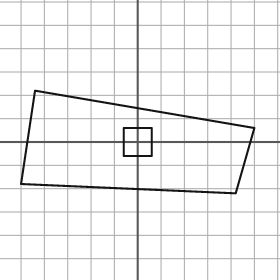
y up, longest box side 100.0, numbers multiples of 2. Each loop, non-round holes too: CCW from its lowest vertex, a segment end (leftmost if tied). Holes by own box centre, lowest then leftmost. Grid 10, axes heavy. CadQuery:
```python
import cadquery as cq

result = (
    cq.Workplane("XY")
    .moveTo(42.0, -22.0)
    .lineTo(50.0, 6.0)
    .lineTo(-44.0, 22.0)
    .lineTo(-50.0, -18.0)
    .close()
    .moveTo(-6.0, -6.0)
    .lineTo(6.0, -6.0)
    .lineTo(6.0, 6.0)
    .lineTo(-6.0, 6.0)
    .close()
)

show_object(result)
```